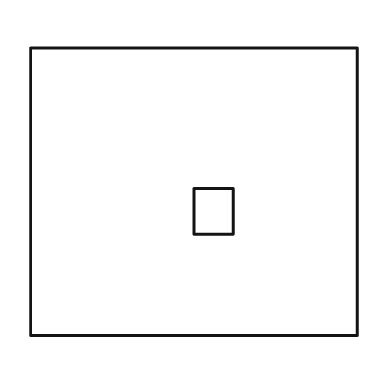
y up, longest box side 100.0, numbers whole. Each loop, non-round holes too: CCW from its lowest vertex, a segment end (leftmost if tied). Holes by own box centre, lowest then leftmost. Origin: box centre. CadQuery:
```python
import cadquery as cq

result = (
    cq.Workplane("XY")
    .moveTo(-50.0, -44.0)
    .lineTo(50.0, -44.0)
    .lineTo(50.0, 44.0)
    .lineTo(-50.0, 44.0)
    .close()
    .moveTo(0.0, -13.0)
    .lineTo(12.0, -13.0)
    .lineTo(12.0, 1.0)
    .lineTo(0.0, 1.0)
    .close()
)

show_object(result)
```